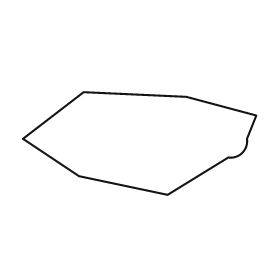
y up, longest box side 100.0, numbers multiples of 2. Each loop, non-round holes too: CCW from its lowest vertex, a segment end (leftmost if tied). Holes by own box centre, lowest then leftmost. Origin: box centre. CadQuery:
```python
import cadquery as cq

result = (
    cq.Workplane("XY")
    .moveTo(12.0, -22.0)
    .lineTo(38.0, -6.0)
    .threePointArc((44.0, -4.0), (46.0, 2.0))
    .lineTo(50.0, 12.0)
    .lineTo(20.0, 20.0)
    .lineTo(-24.0, 22.0)
    .lineTo(-50.0, 2.0)
    .lineTo(-26.0, -14.0)
    .close()
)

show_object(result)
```